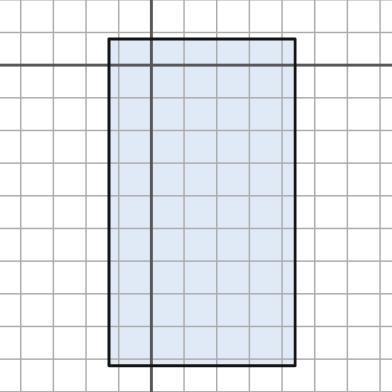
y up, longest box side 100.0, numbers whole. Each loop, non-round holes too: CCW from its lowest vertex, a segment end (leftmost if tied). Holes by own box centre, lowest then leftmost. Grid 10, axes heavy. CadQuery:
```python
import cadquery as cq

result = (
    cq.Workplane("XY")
    .moveTo(-13.0, -92.0)
    .lineTo(44.0, -92.0)
    .lineTo(44.0, 8.0)
    .lineTo(-13.0, 8.0)
    .close()
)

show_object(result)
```